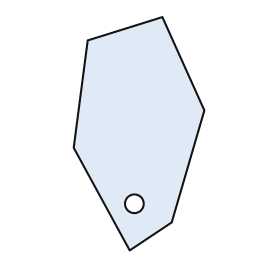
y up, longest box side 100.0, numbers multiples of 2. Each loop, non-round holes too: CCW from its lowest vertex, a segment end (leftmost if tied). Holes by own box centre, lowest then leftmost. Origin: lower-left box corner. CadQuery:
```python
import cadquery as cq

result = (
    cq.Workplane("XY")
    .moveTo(24.0, 0.0)
    .lineTo(42.0, 12.0)
    .lineTo(56.0, 60.0)
    .lineTo(38.0, 100.0)
    .lineTo(6.0, 90.0)
    .lineTo(0.0, 44.0)
    .close()
    .moveTo(26.0, 20.0)
    .circle(4.0)
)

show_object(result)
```